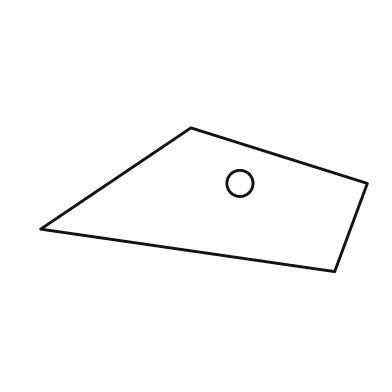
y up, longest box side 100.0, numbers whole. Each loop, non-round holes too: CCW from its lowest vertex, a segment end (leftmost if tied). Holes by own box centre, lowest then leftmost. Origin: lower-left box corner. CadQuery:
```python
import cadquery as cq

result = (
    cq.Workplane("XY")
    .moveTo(90.0, 0.0)
    .lineTo(100.0, 27.0)
    .lineTo(46.0, 44.0)
    .lineTo(0.0, 13.0)
    .close()
    .moveTo(61.0, 27.0)
    .circle(4.0)
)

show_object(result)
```